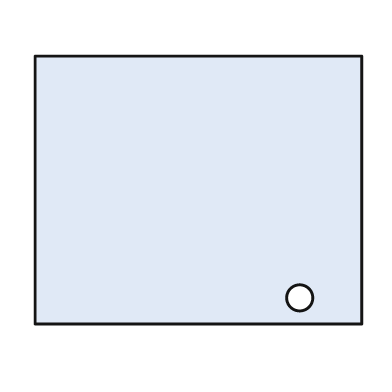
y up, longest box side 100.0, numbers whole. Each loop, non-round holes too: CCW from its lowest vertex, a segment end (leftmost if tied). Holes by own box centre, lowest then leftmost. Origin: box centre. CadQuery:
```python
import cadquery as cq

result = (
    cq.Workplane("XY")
    .moveTo(-50.0, -41.0)
    .lineTo(50.0, -41.0)
    .lineTo(50.0, 41.0)
    .lineTo(-50.0, 41.0)
    .close()
    .moveTo(31.0, -33.0)
    .circle(4.0)
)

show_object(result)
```